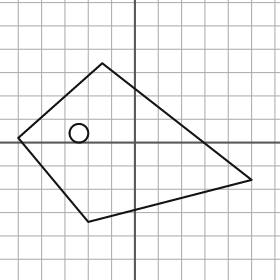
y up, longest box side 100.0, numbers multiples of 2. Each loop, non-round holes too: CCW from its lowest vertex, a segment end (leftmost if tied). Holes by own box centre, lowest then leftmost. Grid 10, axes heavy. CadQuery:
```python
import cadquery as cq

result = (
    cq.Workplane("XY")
    .moveTo(-20.0, -34.0)
    .lineTo(50.0, -16.0)
    .lineTo(-14.0, 34.0)
    .lineTo(-50.0, 2.0)
    .close()
    .moveTo(-24.0, 4.0)
    .circle(4.0)
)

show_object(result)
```